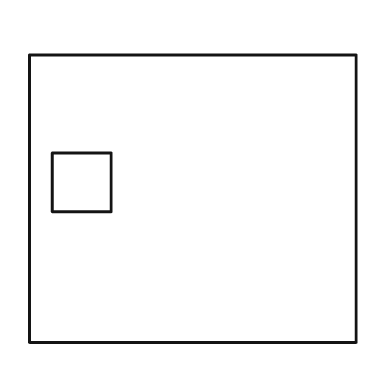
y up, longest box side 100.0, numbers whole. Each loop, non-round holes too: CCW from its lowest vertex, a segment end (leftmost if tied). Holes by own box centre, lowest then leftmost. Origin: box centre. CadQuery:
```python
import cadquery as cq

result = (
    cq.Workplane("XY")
    .moveTo(-50.0, -44.0)
    .lineTo(50.0, -44.0)
    .lineTo(50.0, 44.0)
    .lineTo(-50.0, 44.0)
    .close()
    .moveTo(-43.0, -4.0)
    .lineTo(-25.0, -4.0)
    .lineTo(-25.0, 14.0)
    .lineTo(-43.0, 14.0)
    .close()
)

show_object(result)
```